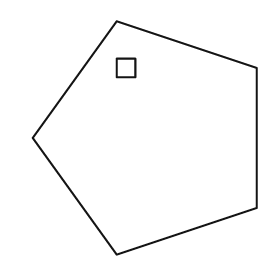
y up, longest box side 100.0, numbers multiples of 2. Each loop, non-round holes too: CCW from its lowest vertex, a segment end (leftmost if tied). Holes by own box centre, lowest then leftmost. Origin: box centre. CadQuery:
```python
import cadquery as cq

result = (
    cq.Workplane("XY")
    .moveTo(-12.0, -50.0)
    .lineTo(48.0, -30.0)
    .lineTo(48.0, 30.0)
    .lineTo(-12.0, 50.0)
    .lineTo(-48.0, 0.0)
    .close()
    .moveTo(-12.0, 26.0)
    .lineTo(-4.0, 26.0)
    .lineTo(-4.0, 34.0)
    .lineTo(-12.0, 34.0)
    .close()
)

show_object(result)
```